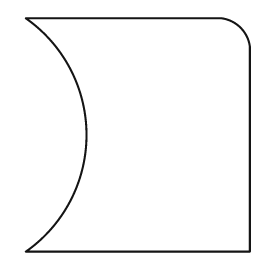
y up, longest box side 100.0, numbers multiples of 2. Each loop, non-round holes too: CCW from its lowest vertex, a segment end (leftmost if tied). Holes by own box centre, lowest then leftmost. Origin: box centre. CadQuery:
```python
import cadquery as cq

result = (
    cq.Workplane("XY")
    .moveTo(-48.0, -50.0)
    .lineTo(48.0, -50.0)
    .lineTo(48.0, 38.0)
    .threePointArc((44.0, 46.0), (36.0, 50.0))
    .lineTo(-48.0, 50.0)
    .threePointArc((-22.0, 0.0), (-48.0, -50.0))
    .close()
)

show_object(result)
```